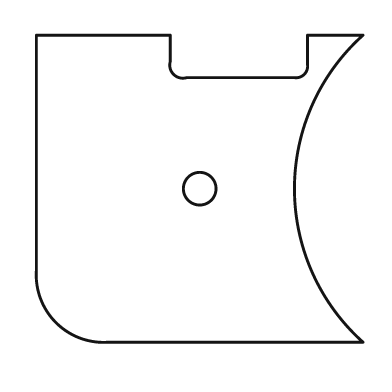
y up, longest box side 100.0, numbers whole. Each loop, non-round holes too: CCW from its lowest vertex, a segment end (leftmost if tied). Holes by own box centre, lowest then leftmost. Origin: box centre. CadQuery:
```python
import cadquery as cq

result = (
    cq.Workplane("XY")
    .moveTo(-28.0, -47.0)
    .lineTo(50.0, -47.0)
    .threePointArc((29.0, 0.0), (50.0, 47.0))
    .lineTo(33.0, 47.0)
    .lineTo(33.0, 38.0)
    .threePointArc((32.0, 35.0), (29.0, 34.0))
    .lineTo(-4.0, 34.0)
    .threePointArc((-8.0, 35.0), (-9.0, 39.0))
    .lineTo(-9.0, 47.0)
    .lineTo(-50.0, 47.0)
    .lineTo(-50.0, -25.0)
    .threePointArc((-44.0, -41.0), (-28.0, -47.0))
    .close()
    .moveTo(0.0, 0.0)
    .circle(5.0)
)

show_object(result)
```